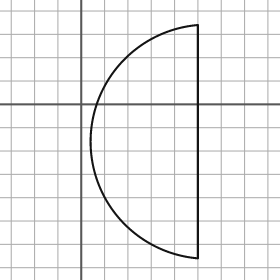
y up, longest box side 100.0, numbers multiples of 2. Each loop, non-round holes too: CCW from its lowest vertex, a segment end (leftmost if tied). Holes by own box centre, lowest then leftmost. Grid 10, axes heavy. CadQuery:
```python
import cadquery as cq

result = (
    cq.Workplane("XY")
    .moveTo(50.0, -66.0)
    .lineTo(50.0, 34.0)
    .threePointArc((4.0, -16.0), (50.0, -66.0))
    .close()
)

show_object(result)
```